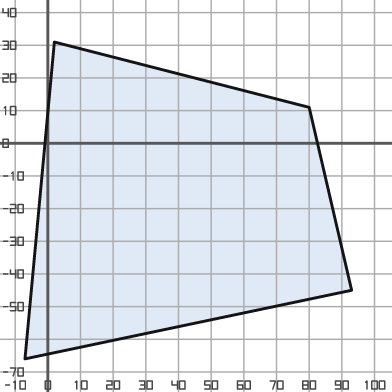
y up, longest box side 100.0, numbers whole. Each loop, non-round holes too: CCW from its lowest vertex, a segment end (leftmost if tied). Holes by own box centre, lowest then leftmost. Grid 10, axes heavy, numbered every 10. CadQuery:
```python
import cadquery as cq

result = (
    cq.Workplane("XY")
    .moveTo(-7.0, -66.0)
    .lineTo(93.0, -45.0)
    .lineTo(80.0, 11.0)
    .lineTo(2.0, 31.0)
    .close()
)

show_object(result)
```